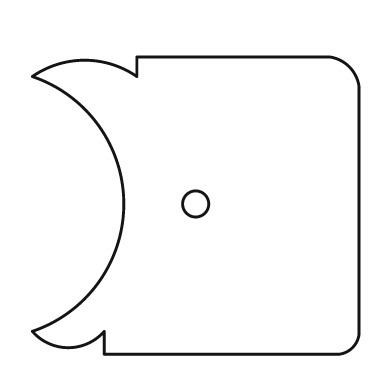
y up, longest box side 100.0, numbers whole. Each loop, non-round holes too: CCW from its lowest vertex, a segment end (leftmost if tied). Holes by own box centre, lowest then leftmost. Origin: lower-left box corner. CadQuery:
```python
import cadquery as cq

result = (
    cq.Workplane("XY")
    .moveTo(22.0, 0.0)
    .lineTo(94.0, 0.0)
    .threePointArc((98.0, 2.0), (100.0, 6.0))
    .lineTo(100.0, 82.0)
    .threePointArc((97.0, 88.0), (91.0, 91.0))
    .lineTo(32.0, 91.0)
    .lineTo(32.0, 85.0)
    .threePointArc((16.0, 90.0), (0.0, 85.0))
    .threePointArc((28.0, 46.0), (0.0, 7.0))
    .threePointArc((11.0, 2.0), (22.0, 7.0))
    .close()
    .moveTo(50.0, 46.0)
    .circle(4.0)
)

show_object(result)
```